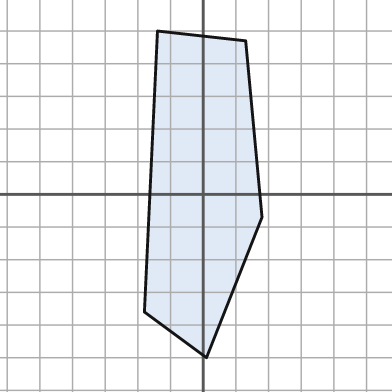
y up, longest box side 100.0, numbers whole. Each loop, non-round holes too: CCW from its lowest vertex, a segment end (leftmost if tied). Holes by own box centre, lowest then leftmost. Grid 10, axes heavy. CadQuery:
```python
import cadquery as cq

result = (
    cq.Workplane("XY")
    .moveTo(1.0, -50.0)
    .lineTo(18.0, -7.0)
    .lineTo(13.0, 47.0)
    .lineTo(-14.0, 50.0)
    .lineTo(-18.0, -36.0)
    .close()
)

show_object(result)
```